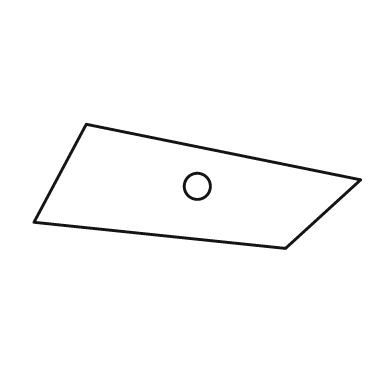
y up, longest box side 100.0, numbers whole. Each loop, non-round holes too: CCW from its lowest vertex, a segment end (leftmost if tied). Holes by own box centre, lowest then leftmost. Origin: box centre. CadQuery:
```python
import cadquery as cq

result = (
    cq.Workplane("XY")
    .moveTo(27.0, -19.0)
    .lineTo(50.0, 2.0)
    .lineTo(-34.0, 19.0)
    .lineTo(-50.0, -11.0)
    .close()
    .moveTo(0.0, 0.0)
    .circle(4.0)
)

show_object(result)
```